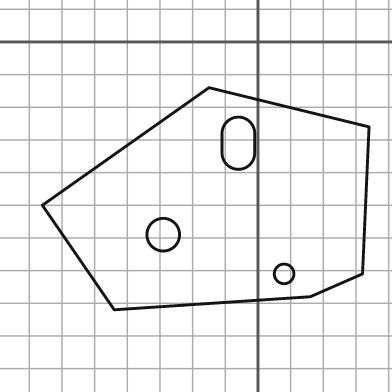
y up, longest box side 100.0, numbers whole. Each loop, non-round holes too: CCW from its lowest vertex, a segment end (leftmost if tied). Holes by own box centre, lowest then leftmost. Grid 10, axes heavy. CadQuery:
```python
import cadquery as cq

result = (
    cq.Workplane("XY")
    .moveTo(-44.0, -82.0)
    .lineTo(16.0, -78.0)
    .lineTo(32.0, -71.0)
    .lineTo(34.0, -26.0)
    .lineTo(-15.0, -14.0)
    .lineTo(-66.0, -50.0)
    .close()
    .moveTo(8.0, -71.0)
    .circle(3.0)
    .moveTo(-29.0, -59.0)
    .circle(5.0)
    .moveTo(-11.0, -34.0)
    .threePointArc((-6.0, -39.0), (-1.0, -34.0))
    .lineTo(-1.0, -28.0)
    .threePointArc((-6.0, -23.0), (-11.0, -28.0))
    .close()
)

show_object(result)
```